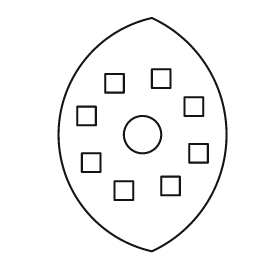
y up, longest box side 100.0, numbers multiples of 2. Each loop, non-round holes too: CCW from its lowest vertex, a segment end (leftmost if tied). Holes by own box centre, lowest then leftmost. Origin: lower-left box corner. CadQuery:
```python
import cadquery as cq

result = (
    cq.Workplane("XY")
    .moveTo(40.0, 0.0)
    .threePointArc((72.0, 50.0), (40.0, 100.0))
    .threePointArc((0.0, 50.0), (40.0, 0.0))
    .close()
    .moveTo(24.0, 22.0)
    .lineTo(32.0, 22.0)
    .lineTo(32.0, 30.0)
    .lineTo(24.0, 30.0)
    .close()
    .moveTo(44.0, 24.0)
    .lineTo(52.0, 24.0)
    .lineTo(52.0, 32.0)
    .lineTo(44.0, 32.0)
    .close()
    .moveTo(10.0, 34.0)
    .lineTo(18.0, 34.0)
    .lineTo(18.0, 42.0)
    .lineTo(10.0, 42.0)
    .close()
    .moveTo(56.0, 38.0)
    .lineTo(64.0, 38.0)
    .lineTo(64.0, 46.0)
    .lineTo(56.0, 46.0)
    .close()
    .moveTo(36.0, 50.0)
    .circle(8.0)
    .moveTo(8.0, 54.0)
    .lineTo(16.0, 54.0)
    .lineTo(16.0, 62.0)
    .lineTo(8.0, 62.0)
    .close()
    .moveTo(54.0, 58.0)
    .lineTo(62.0, 58.0)
    .lineTo(62.0, 66.0)
    .lineTo(54.0, 66.0)
    .close()
    .moveTo(20.0, 68.0)
    .lineTo(28.0, 68.0)
    .lineTo(28.0, 76.0)
    .lineTo(20.0, 76.0)
    .close()
    .moveTo(40.0, 70.0)
    .lineTo(48.0, 70.0)
    .lineTo(48.0, 78.0)
    .lineTo(40.0, 78.0)
    .close()
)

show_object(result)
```